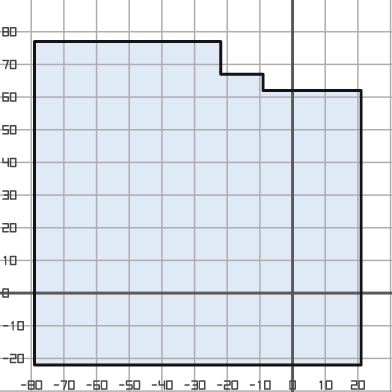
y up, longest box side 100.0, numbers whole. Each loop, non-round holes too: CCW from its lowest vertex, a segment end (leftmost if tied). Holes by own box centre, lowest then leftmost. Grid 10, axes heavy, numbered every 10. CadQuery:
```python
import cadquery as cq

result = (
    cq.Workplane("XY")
    .moveTo(-79.0, -22.0)
    .lineTo(21.0, -22.0)
    .lineTo(21.0, 62.0)
    .lineTo(-9.0, 62.0)
    .lineTo(-9.0, 67.0)
    .lineTo(-22.0, 67.0)
    .lineTo(-22.0, 77.0)
    .lineTo(-79.0, 77.0)
    .close()
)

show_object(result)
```